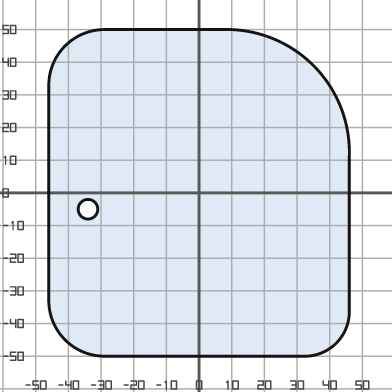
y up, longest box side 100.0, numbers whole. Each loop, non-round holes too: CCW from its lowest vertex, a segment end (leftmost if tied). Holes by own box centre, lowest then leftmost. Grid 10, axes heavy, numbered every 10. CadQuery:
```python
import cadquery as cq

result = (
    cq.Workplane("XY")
    .moveTo(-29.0, -50.0)
    .lineTo(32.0, -50.0)
    .threePointArc((42.0, -46.0), (46.0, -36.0))
    .lineTo(46.0, 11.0)
    .threePointArc((35.0, 39.0), (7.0, 50.0))
    .lineTo(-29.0, 50.0)
    .threePointArc((-41.0, 45.0), (-46.0, 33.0))
    .lineTo(-46.0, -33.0)
    .threePointArc((-41.0, -45.0), (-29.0, -50.0))
    .close()
    .moveTo(-34.0, -5.0)
    .circle(3.0)
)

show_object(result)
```